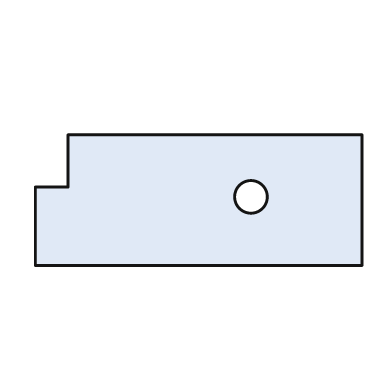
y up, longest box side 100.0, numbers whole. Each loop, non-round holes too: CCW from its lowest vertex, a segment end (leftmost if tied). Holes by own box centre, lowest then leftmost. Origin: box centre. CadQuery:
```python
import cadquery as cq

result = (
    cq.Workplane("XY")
    .moveTo(-50.0, -20.0)
    .lineTo(50.0, -20.0)
    .lineTo(50.0, 20.0)
    .lineTo(-40.0, 20.0)
    .lineTo(-40.0, 4.0)
    .lineTo(-50.0, 4.0)
    .close()
    .moveTo(16.0, 1.0)
    .circle(5.0)
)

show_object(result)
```